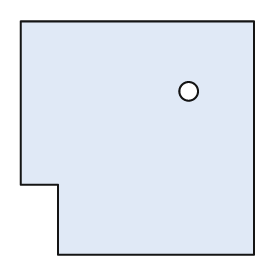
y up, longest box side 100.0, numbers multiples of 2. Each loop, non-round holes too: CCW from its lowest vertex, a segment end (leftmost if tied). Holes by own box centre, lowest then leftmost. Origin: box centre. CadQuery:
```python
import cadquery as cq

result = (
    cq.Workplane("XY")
    .moveTo(-34.0, -50.0)
    .lineTo(50.0, -50.0)
    .lineTo(50.0, 50.0)
    .lineTo(-50.0, 50.0)
    .lineTo(-50.0, -20.0)
    .lineTo(-34.0, -20.0)
    .close()
    .moveTo(22.0, 20.0)
    .circle(4.0)
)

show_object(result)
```